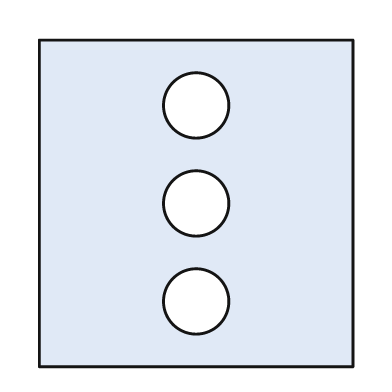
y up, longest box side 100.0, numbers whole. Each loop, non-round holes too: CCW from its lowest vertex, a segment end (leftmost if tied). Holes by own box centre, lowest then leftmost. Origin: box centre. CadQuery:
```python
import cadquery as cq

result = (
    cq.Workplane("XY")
    .moveTo(-48.0, -50.0)
    .lineTo(48.0, -50.0)
    .lineTo(48.0, 50.0)
    .lineTo(-48.0, 50.0)
    .close()
    .moveTo(0.0, -30.0)
    .circle(10.0)
    .moveTo(0.0, 0.0)
    .circle(10.0)
    .moveTo(0.0, 30.0)
    .circle(10.0)
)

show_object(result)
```